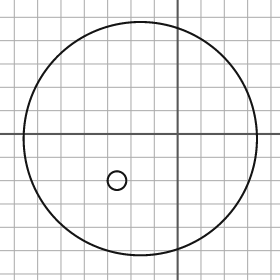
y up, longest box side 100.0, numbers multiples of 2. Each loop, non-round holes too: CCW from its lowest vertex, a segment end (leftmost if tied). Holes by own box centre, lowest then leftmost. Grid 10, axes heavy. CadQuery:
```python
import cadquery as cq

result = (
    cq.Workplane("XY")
    .moveTo(-16.0, -2.0)
    .circle(50.0)
    .moveTo(-26.0, -20.0)
    .circle(4.0)
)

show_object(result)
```